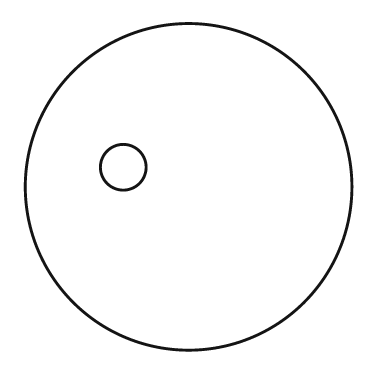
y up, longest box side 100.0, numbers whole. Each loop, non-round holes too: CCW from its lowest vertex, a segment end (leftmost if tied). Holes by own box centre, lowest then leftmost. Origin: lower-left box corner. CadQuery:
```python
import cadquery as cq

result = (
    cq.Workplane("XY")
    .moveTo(50.0, 50.0)
    .circle(50.0)
    .moveTo(30.0, 56.0)
    .circle(7.0)
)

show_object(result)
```